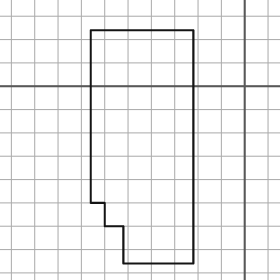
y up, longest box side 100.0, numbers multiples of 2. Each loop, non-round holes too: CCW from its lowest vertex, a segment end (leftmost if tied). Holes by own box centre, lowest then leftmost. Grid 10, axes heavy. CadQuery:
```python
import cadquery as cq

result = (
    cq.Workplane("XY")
    .moveTo(-52.0, -76.0)
    .lineTo(-22.0, -76.0)
    .lineTo(-22.0, 24.0)
    .lineTo(-66.0, 24.0)
    .lineTo(-66.0, -50.0)
    .lineTo(-60.0, -50.0)
    .lineTo(-60.0, -60.0)
    .lineTo(-52.0, -60.0)
    .close()
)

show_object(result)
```